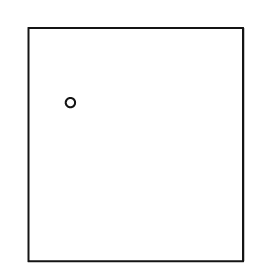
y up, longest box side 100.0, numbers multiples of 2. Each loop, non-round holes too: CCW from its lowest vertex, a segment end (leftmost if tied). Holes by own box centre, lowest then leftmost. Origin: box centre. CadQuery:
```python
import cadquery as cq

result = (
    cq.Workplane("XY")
    .moveTo(-46.0, -50.0)
    .lineTo(46.0, -50.0)
    .lineTo(46.0, 50.0)
    .lineTo(-46.0, 50.0)
    .close()
    .moveTo(-28.0, 18.0)
    .circle(2.0)
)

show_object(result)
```